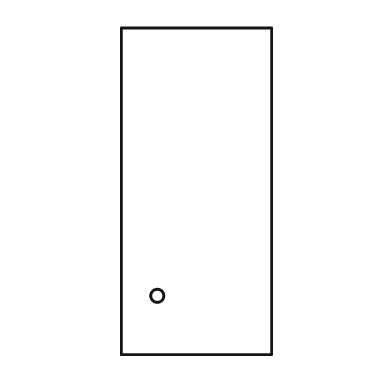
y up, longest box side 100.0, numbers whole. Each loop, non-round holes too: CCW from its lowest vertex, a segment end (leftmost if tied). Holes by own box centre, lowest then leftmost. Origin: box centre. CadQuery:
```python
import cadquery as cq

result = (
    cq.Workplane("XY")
    .moveTo(-23.0, -50.0)
    .lineTo(23.0, -50.0)
    .lineTo(23.0, 50.0)
    .lineTo(-23.0, 50.0)
    .close()
    .moveTo(-12.0, -32.0)
    .circle(2.0)
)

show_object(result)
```